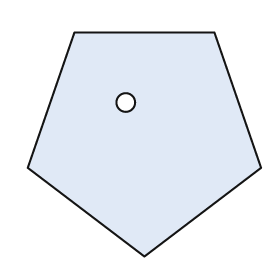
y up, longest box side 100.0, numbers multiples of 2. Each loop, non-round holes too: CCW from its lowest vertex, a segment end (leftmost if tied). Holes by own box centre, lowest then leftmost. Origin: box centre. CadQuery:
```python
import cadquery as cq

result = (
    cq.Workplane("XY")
    .moveTo(0.0, -48.0)
    .lineTo(50.0, -10.0)
    .lineTo(30.0, 48.0)
    .lineTo(-30.0, 48.0)
    .lineTo(-50.0, -10.0)
    .close()
    .moveTo(-8.0, 18.0)
    .circle(4.0)
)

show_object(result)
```